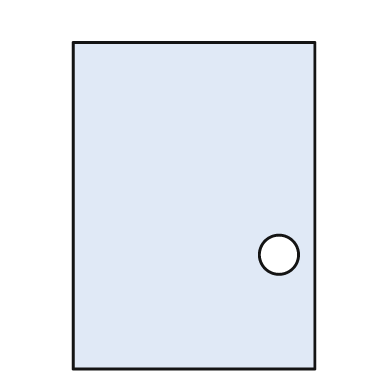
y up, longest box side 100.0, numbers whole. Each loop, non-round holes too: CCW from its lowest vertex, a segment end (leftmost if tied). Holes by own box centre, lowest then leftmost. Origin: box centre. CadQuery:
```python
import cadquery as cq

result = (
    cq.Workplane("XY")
    .moveTo(-37.0, -50.0)
    .lineTo(37.0, -50.0)
    .lineTo(37.0, 50.0)
    .lineTo(-37.0, 50.0)
    .close()
    .moveTo(26.0, -15.0)
    .circle(6.0)
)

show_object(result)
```